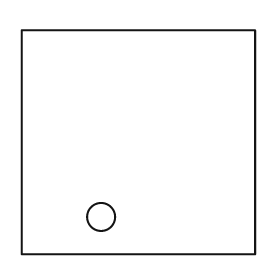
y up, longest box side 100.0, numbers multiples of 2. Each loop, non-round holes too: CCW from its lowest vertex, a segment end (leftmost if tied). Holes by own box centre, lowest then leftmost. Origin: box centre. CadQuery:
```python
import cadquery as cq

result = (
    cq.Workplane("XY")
    .moveTo(-50.0, -48.0)
    .lineTo(50.0, -48.0)
    .lineTo(50.0, 48.0)
    .lineTo(-50.0, 48.0)
    .close()
    .moveTo(-16.0, -32.0)
    .circle(6.0)
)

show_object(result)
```